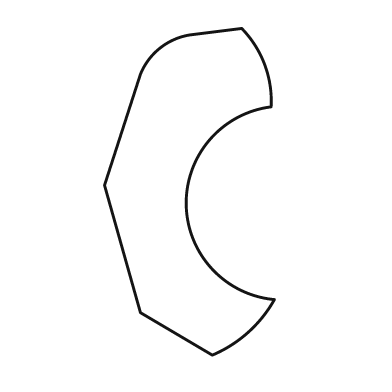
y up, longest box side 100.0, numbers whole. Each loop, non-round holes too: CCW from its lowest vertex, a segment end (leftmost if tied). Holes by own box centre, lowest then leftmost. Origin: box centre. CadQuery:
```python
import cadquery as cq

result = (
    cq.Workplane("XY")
    .moveTo(7.0, -50.0)
    .threePointArc((18.0, -43.0), (26.0, -33.0))
    .threePointArc((-1.0, -4.0), (25.0, 26.0))
    .threePointArc((23.0, 39.0), (16.0, 50.0))
    .lineTo(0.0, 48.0)
    .threePointArc((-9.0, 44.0), (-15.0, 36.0))
    .lineTo(-26.0, 2.0)
    .lineTo(-15.0, -37.0)
    .close()
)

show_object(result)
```